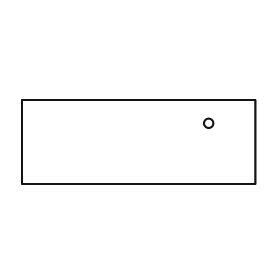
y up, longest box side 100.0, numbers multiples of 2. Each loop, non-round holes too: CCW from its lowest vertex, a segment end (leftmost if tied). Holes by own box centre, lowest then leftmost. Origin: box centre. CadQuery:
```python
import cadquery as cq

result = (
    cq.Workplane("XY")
    .moveTo(-50.0, -18.0)
    .lineTo(50.0, -18.0)
    .lineTo(50.0, 18.0)
    .lineTo(-50.0, 18.0)
    .close()
    .moveTo(30.0, 8.0)
    .circle(2.0)
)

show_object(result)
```